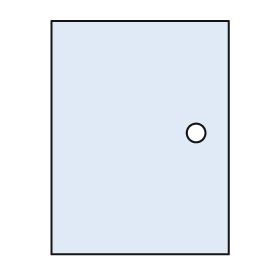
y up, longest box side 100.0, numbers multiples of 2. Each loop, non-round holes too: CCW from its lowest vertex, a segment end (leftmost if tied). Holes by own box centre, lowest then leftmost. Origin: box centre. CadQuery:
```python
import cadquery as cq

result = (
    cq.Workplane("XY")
    .moveTo(-38.0, -50.0)
    .lineTo(38.0, -50.0)
    .lineTo(38.0, 50.0)
    .lineTo(-38.0, 50.0)
    .close()
    .moveTo(24.0, 2.0)
    .circle(4.0)
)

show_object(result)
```